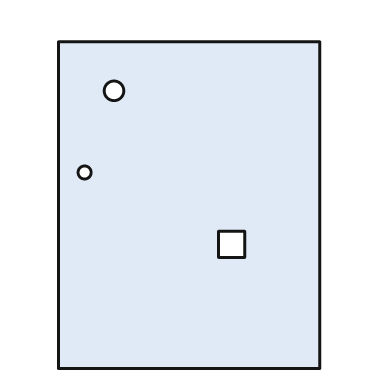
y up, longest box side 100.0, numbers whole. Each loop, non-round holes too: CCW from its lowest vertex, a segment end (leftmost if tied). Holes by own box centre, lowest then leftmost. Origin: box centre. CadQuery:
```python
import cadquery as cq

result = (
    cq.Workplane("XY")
    .moveTo(-40.0, -50.0)
    .lineTo(40.0, -50.0)
    .lineTo(40.0, 50.0)
    .lineTo(-40.0, 50.0)
    .close()
    .moveTo(9.0, -16.0)
    .lineTo(17.0, -16.0)
    .lineTo(17.0, -8.0)
    .lineTo(9.0, -8.0)
    .close()
    .moveTo(-32.0, 10.0)
    .circle(2.0)
    .moveTo(-23.0, 35.0)
    .circle(3.0)
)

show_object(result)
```